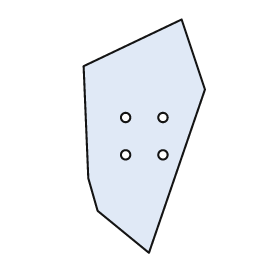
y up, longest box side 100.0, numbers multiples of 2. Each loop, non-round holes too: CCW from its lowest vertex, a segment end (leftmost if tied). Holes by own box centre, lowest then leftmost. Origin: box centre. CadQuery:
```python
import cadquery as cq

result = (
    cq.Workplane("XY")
    .moveTo(2.0, -50.0)
    .lineTo(26.0, 20.0)
    .lineTo(16.0, 50.0)
    .lineTo(-26.0, 30.0)
    .lineTo(-24.0, -18.0)
    .lineTo(-20.0, -32.0)
    .close()
    .moveTo(-8.0, -8.0)
    .circle(2.0)
    .moveTo(8.0, -8.0)
    .circle(2.0)
    .moveTo(-8.0, 8.0)
    .circle(2.0)
    .moveTo(8.0, 8.0)
    .circle(2.0)
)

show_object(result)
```